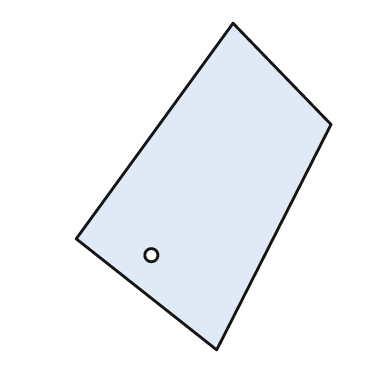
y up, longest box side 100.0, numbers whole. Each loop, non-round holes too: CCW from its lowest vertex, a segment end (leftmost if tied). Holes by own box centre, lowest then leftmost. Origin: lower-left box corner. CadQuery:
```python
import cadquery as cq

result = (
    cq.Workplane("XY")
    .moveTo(43.0, 0.0)
    .lineTo(78.0, 69.0)
    .lineTo(48.0, 100.0)
    .lineTo(0.0, 34.0)
    .close()
    .moveTo(23.0, 29.0)
    .circle(2.0)
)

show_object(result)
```